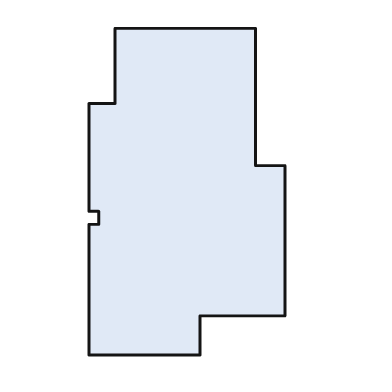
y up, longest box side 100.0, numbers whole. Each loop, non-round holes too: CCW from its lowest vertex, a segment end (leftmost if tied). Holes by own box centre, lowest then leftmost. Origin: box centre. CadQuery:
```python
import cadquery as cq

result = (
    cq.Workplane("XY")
    .moveTo(-30.0, -50.0)
    .lineTo(4.0, -50.0)
    .lineTo(4.0, -38.0)
    .lineTo(30.0, -38.0)
    .lineTo(30.0, 8.0)
    .lineTo(21.0, 8.0)
    .lineTo(21.0, 50.0)
    .lineTo(-22.0, 50.0)
    .lineTo(-22.0, 27.0)
    .lineTo(-30.0, 27.0)
    .lineTo(-30.0, -6.0)
    .lineTo(-27.0, -6.0)
    .lineTo(-27.0, -10.0)
    .lineTo(-30.0, -10.0)
    .close()
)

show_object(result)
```